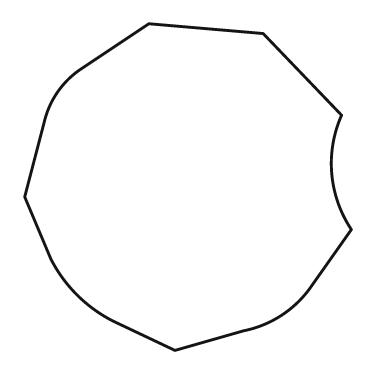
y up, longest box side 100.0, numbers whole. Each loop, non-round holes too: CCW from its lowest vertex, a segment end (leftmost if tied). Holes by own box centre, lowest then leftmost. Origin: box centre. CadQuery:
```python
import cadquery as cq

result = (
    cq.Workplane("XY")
    .moveTo(-4.0, -50.0)
    .lineTo(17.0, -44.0)
    .threePointArc((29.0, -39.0), (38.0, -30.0))
    .lineTo(50.0, -13.0)
    .threePointArc((44.0, 4.0), (47.0, 22.0))
    .lineTo(23.0, 47.0)
    .lineTo(-12.0, 50.0)
    .lineTo(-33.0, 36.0)
    .threePointArc((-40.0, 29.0), (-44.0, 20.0))
    .lineTo(-50.0, -3.0)
    .lineTo(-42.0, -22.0)
    .threePointArc((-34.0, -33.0), (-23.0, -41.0))
    .close()
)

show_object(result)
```